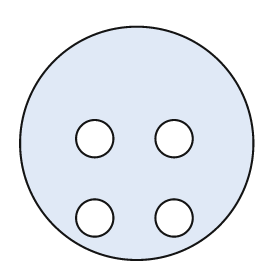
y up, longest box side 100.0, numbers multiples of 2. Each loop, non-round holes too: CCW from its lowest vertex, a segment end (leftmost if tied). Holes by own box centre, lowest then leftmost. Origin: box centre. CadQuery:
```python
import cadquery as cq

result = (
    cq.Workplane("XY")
    .moveTo(0.0, 0.0)
    .circle(50.0)
    .moveTo(-18.0, -32.0)
    .circle(8.0)
    .moveTo(16.0, -32.0)
    .circle(8.0)
    .moveTo(-18.0, 2.0)
    .circle(8.0)
    .moveTo(16.0, 2.0)
    .circle(8.0)
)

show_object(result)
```